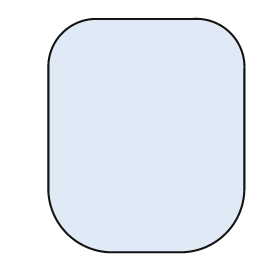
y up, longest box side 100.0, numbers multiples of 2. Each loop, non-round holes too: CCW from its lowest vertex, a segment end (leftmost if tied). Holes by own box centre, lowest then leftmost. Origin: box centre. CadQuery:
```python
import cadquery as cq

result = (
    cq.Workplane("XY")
    .moveTo(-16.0, -50.0)
    .lineTo(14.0, -50.0)
    .threePointArc((34.0, -42.0), (42.0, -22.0))
    .lineTo(42.0, 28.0)
    .threePointArc((36.0, 44.0), (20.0, 50.0))
    .lineTo(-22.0, 50.0)
    .threePointArc((-36.0, 44.0), (-42.0, 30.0))
    .lineTo(-42.0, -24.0)
    .threePointArc((-34.0, -42.0), (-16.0, -50.0))
    .close()
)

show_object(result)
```